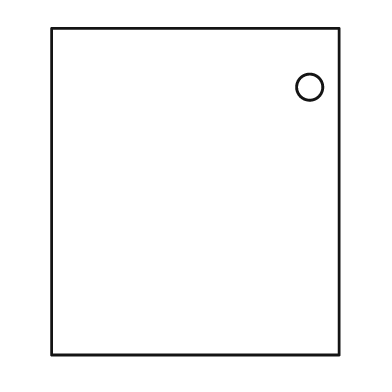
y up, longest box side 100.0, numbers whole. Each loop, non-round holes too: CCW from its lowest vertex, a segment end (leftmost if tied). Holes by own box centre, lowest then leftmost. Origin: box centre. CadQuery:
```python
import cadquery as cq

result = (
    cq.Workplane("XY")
    .moveTo(-44.0, -50.0)
    .lineTo(44.0, -50.0)
    .lineTo(44.0, 50.0)
    .lineTo(-44.0, 50.0)
    .close()
    .moveTo(35.0, 32.0)
    .circle(4.0)
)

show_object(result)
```